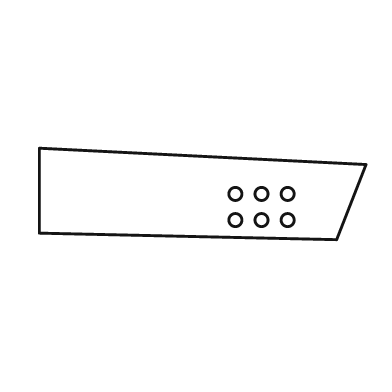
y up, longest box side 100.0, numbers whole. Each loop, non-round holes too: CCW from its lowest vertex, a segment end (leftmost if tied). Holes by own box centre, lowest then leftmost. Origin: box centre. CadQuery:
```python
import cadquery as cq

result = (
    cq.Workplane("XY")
    .moveTo(41.0, -14.0)
    .lineTo(50.0, 9.0)
    .lineTo(-50.0, 14.0)
    .lineTo(-50.0, -12.0)
    .close()
    .moveTo(10.0, -8.0)
    .circle(2.0)
    .moveTo(18.0, -8.0)
    .circle(2.0)
    .moveTo(26.0, -8.0)
    .circle(2.0)
    .moveTo(10.0, 0.0)
    .circle(2.0)
    .moveTo(18.0, 0.0)
    .circle(2.0)
    .moveTo(26.0, 0.0)
    .circle(2.0)
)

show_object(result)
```